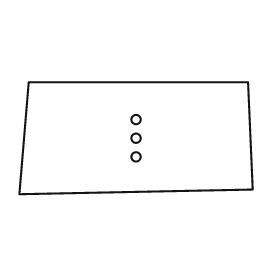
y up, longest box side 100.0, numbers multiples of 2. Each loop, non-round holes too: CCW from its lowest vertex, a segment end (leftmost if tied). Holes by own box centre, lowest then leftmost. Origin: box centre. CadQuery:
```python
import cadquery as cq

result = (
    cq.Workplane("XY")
    .moveTo(-50.0, -24.0)
    .lineTo(50.0, -22.0)
    .lineTo(48.0, 24.0)
    .lineTo(-46.0, 24.0)
    .close()
    .moveTo(0.0, -8.0)
    .circle(2.0)
    .moveTo(0.0, 0.0)
    .circle(2.0)
    .moveTo(0.0, 8.0)
    .circle(2.0)
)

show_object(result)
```